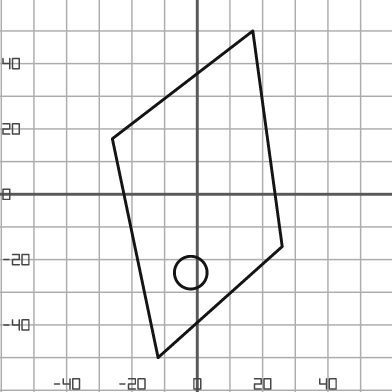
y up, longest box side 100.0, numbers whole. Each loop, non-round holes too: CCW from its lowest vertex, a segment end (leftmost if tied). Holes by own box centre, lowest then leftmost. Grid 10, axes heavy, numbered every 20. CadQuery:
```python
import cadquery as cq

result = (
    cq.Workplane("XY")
    .moveTo(-12.0, -50.0)
    .lineTo(26.0, -16.0)
    .lineTo(17.0, 50.0)
    .lineTo(-26.0, 17.0)
    .close()
    .moveTo(-2.0, -24.0)
    .circle(5.0)
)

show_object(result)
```